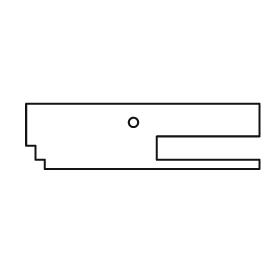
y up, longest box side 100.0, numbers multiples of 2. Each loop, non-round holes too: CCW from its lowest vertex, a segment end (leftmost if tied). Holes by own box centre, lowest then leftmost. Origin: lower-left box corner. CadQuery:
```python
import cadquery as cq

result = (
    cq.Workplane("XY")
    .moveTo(8.0, 0.0)
    .lineTo(100.0, 0.0)
    .lineTo(100.0, 4.0)
    .lineTo(56.0, 4.0)
    .lineTo(56.0, 14.0)
    .lineTo(100.0, 14.0)
    .lineTo(100.0, 28.0)
    .lineTo(0.0, 28.0)
    .lineTo(0.0, 10.0)
    .lineTo(4.0, 10.0)
    .lineTo(4.0, 4.0)
    .lineTo(8.0, 4.0)
    .close()
    .moveTo(46.0, 20.0)
    .circle(2.0)
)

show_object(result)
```